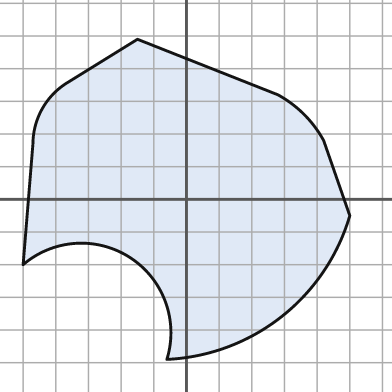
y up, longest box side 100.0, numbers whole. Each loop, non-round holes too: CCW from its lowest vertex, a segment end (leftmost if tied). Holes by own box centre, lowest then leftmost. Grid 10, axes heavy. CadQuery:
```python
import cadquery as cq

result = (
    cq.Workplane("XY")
    .moveTo(-6.0, -49.0)
    .threePointArc((29.0, -36.0), (50.0, -5.0))
    .lineTo(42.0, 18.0)
    .threePointArc((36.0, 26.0), (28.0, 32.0))
    .lineTo(-15.0, 49.0)
    .lineTo(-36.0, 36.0)
    .threePointArc((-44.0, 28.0), (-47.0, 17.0))
    .lineTo(-50.0, -20.0)
    .threePointArc((-17.0, -18.0), (-6.0, -49.0))
    .close()
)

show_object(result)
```